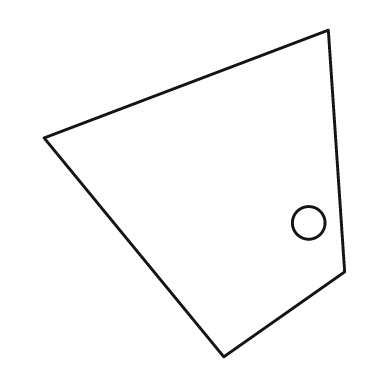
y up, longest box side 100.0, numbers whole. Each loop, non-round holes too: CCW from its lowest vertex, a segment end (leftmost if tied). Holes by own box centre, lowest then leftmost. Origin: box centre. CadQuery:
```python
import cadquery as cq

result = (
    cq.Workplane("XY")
    .moveTo(9.0, -50.0)
    .lineTo(46.0, -24.0)
    .lineTo(41.0, 50.0)
    .lineTo(-46.0, 17.0)
    .close()
    .moveTo(35.0, -9.0)
    .circle(5.0)
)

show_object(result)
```